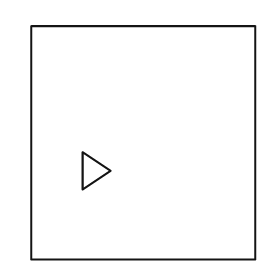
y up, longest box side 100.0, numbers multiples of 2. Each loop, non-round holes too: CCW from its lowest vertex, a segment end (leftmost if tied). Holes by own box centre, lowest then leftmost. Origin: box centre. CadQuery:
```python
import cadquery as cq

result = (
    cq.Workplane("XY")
    .moveTo(-48.0, -50.0)
    .lineTo(48.0, -50.0)
    .lineTo(48.0, 50.0)
    .lineTo(-48.0, 50.0)
    .close()
    .moveTo(-26.0, -20.0)
    .lineTo(-14.0, -12.0)
    .lineTo(-26.0, -4.0)
    .close()
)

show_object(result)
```